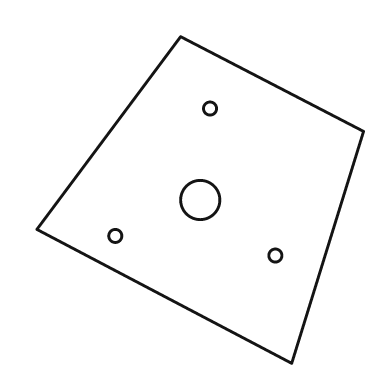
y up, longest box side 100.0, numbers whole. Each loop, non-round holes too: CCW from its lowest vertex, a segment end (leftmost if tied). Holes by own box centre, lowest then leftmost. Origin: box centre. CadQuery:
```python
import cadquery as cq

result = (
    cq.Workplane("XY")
    .moveTo(28.0, -50.0)
    .lineTo(50.0, 21.0)
    .lineTo(-6.0, 50.0)
    .lineTo(-50.0, -9.0)
    .close()
    .moveTo(23.0, -17.0)
    .circle(2.0)
    .moveTo(-26.0, -11.0)
    .circle(2.0)
    .moveTo(0.0, 0.0)
    .circle(6.0)
    .moveTo(3.0, 28.0)
    .circle(2.0)
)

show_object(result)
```